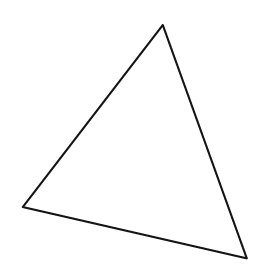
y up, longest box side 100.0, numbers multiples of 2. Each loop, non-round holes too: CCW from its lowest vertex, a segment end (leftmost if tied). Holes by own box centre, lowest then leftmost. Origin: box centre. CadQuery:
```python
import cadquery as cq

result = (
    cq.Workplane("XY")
    .moveTo(48.0, -50.0)
    .lineTo(12.0, 50.0)
    .lineTo(-48.0, -28.0)
    .close()
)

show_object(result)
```